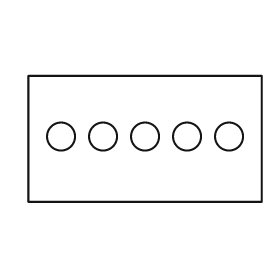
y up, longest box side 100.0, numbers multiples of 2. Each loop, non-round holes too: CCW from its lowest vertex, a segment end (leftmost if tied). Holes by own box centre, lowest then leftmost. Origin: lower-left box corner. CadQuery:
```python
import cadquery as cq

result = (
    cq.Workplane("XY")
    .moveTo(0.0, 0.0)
    .lineTo(100.0, 0.0)
    .lineTo(100.0, 54.0)
    .lineTo(0.0, 54.0)
    .close()
    .moveTo(14.0, 28.0)
    .circle(6.0)
    .moveTo(32.0, 28.0)
    .circle(6.0)
    .moveTo(50.0, 28.0)
    .circle(6.0)
    .moveTo(68.0, 28.0)
    .circle(6.0)
    .moveTo(86.0, 28.0)
    .circle(6.0)
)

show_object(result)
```